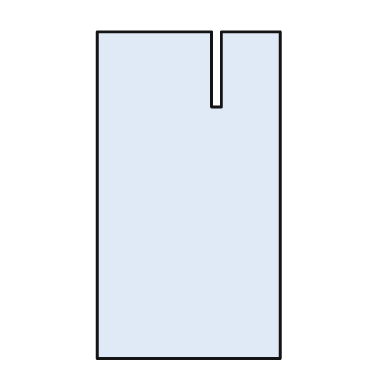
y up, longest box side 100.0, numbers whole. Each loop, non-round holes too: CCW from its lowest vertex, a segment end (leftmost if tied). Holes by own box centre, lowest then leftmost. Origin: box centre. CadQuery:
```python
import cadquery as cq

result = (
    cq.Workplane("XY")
    .moveTo(-28.0, -50.0)
    .lineTo(28.0, -50.0)
    .lineTo(28.0, 50.0)
    .lineTo(10.0, 50.0)
    .lineTo(10.0, 27.0)
    .lineTo(7.0, 27.0)
    .lineTo(7.0, 50.0)
    .lineTo(-28.0, 50.0)
    .close()
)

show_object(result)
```